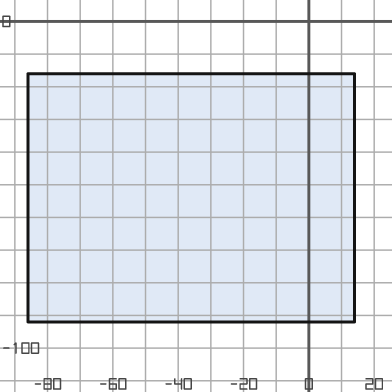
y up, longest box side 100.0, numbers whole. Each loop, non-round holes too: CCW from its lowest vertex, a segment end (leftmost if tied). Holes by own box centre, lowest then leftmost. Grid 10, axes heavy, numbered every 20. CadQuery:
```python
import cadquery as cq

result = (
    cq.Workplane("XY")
    .moveTo(-86.0, -92.0)
    .lineTo(14.0, -92.0)
    .lineTo(14.0, -16.0)
    .lineTo(-86.0, -16.0)
    .close()
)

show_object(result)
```